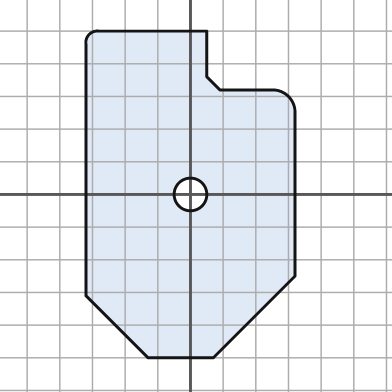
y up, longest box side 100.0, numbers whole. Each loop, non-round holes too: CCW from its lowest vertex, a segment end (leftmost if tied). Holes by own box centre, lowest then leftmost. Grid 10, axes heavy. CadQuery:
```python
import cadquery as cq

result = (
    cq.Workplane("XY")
    .moveTo(-13.0, -50.0)
    .lineTo(7.0, -50.0)
    .lineTo(32.0, -25.0)
    .lineTo(32.0, 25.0)
    .threePointArc((30.0, 30.0), (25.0, 32.0))
    .lineTo(9.0, 32.0)
    .lineTo(5.0, 36.0)
    .lineTo(5.0, 50.0)
    .lineTo(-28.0, 50.0)
    .threePointArc((-31.0, 49.0), (-32.0, 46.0))
    .lineTo(-32.0, -31.0)
    .close()
    .moveTo(0.0, 0.0)
    .circle(5.0)
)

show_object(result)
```